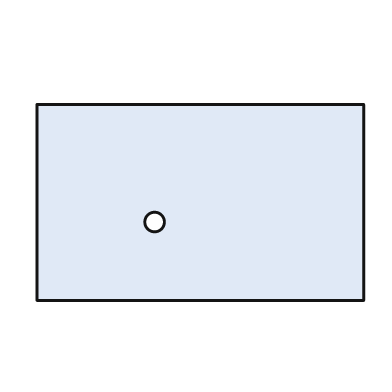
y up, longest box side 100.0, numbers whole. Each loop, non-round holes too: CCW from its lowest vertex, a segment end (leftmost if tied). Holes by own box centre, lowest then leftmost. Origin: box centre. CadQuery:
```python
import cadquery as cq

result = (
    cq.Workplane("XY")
    .moveTo(-50.0, -30.0)
    .lineTo(50.0, -30.0)
    .lineTo(50.0, 30.0)
    .lineTo(-50.0, 30.0)
    .close()
    .moveTo(-14.0, -6.0)
    .circle(3.0)
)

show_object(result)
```